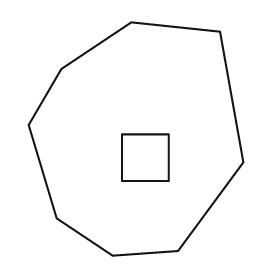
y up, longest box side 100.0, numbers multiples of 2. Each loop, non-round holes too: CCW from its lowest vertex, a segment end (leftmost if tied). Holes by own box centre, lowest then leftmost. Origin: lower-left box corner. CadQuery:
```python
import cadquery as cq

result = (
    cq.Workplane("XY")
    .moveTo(36.0, 0.0)
    .lineTo(64.0, 2.0)
    .lineTo(92.0, 40.0)
    .lineTo(82.0, 96.0)
    .lineTo(44.0, 100.0)
    .lineTo(14.0, 80.0)
    .lineTo(0.0, 56.0)
    .lineTo(12.0, 16.0)
    .close()
    .moveTo(40.0, 32.0)
    .lineTo(60.0, 32.0)
    .lineTo(60.0, 52.0)
    .lineTo(40.0, 52.0)
    .close()
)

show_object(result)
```